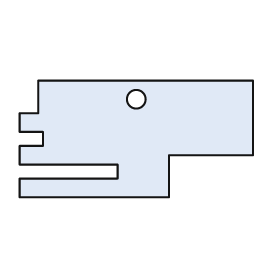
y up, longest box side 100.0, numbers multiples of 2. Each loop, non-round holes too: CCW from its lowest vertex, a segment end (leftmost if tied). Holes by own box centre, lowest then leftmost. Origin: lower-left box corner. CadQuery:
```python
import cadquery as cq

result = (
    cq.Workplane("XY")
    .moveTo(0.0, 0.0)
    .lineTo(64.0, 0.0)
    .lineTo(64.0, 18.0)
    .lineTo(100.0, 18.0)
    .lineTo(100.0, 50.0)
    .lineTo(8.0, 50.0)
    .lineTo(8.0, 36.0)
    .lineTo(0.0, 36.0)
    .lineTo(0.0, 28.0)
    .lineTo(10.0, 28.0)
    .lineTo(10.0, 22.0)
    .lineTo(0.0, 22.0)
    .lineTo(0.0, 14.0)
    .lineTo(42.0, 14.0)
    .lineTo(42.0, 8.0)
    .lineTo(0.0, 8.0)
    .close()
    .moveTo(50.0, 42.0)
    .circle(4.0)
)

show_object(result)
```